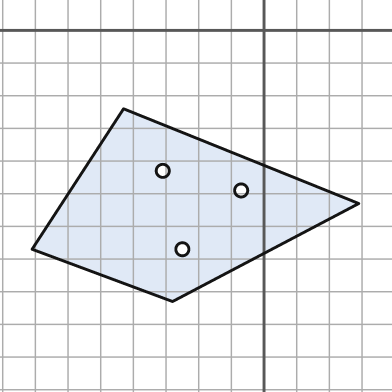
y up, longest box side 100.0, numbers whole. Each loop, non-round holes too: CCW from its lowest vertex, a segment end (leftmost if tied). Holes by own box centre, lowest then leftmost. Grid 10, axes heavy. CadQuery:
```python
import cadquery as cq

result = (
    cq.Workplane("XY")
    .moveTo(-28.0, -83.0)
    .lineTo(29.0, -53.0)
    .lineTo(-43.0, -24.0)
    .lineTo(-71.0, -67.0)
    .close()
    .moveTo(-25.0, -67.0)
    .circle(2.0)
    .moveTo(-7.0, -49.0)
    .circle(2.0)
    .moveTo(-31.0, -43.0)
    .circle(2.0)
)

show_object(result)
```